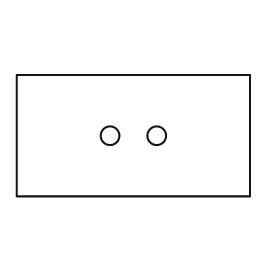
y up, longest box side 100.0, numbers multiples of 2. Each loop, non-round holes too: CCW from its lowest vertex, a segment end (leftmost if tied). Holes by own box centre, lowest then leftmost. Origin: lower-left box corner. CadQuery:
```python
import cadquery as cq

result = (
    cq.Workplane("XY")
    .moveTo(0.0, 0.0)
    .lineTo(100.0, 0.0)
    .lineTo(100.0, 52.0)
    .lineTo(0.0, 52.0)
    .close()
    .moveTo(40.0, 26.0)
    .circle(4.0)
    .moveTo(60.0, 26.0)
    .circle(4.0)
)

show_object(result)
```